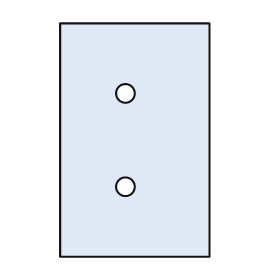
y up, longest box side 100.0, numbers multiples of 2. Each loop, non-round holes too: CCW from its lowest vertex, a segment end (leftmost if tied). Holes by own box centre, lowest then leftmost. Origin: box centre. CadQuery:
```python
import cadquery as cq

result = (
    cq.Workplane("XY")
    .moveTo(-32.0, -50.0)
    .lineTo(32.0, -50.0)
    .lineTo(32.0, 50.0)
    .lineTo(-32.0, 50.0)
    .close()
    .moveTo(-4.0, -20.0)
    .circle(4.0)
    .moveTo(-4.0, 20.0)
    .circle(4.0)
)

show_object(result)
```